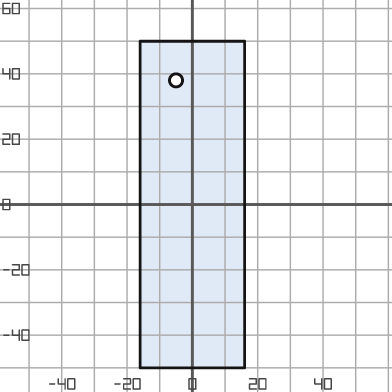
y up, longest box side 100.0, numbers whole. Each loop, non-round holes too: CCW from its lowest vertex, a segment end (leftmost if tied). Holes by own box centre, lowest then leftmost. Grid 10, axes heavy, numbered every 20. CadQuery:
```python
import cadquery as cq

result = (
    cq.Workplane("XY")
    .moveTo(-16.0, -50.0)
    .lineTo(16.0, -50.0)
    .lineTo(16.0, 50.0)
    .lineTo(-16.0, 50.0)
    .close()
    .moveTo(-5.0, 38.0)
    .circle(2.0)
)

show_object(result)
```